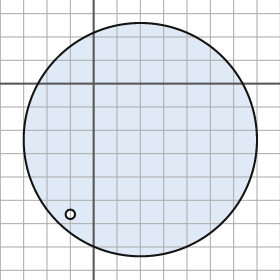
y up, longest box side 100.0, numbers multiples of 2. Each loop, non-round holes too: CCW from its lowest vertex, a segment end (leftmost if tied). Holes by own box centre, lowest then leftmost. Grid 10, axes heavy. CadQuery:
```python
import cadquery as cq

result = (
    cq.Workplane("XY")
    .moveTo(20.0, -24.0)
    .circle(50.0)
    .moveTo(-10.0, -56.0)
    .circle(2.0)
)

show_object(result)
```